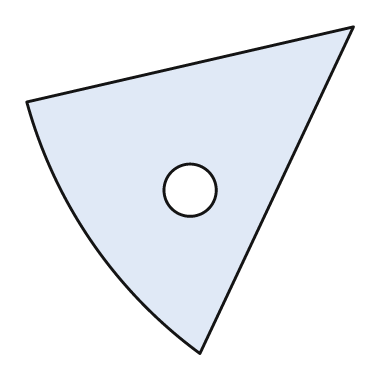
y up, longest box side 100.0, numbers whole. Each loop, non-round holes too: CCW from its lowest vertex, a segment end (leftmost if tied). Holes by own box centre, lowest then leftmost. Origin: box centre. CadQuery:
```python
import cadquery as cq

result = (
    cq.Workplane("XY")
    .moveTo(3.0, -50.0)
    .lineTo(50.0, 50.0)
    .lineTo(-50.0, 27.0)
    .threePointArc((-30.0, -16.0), (3.0, -50.0))
    .close()
    .moveTo(0.0, 0.0)
    .circle(8.0)
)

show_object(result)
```